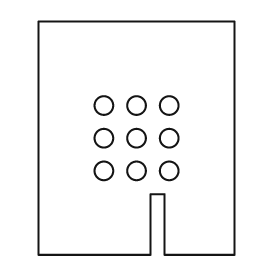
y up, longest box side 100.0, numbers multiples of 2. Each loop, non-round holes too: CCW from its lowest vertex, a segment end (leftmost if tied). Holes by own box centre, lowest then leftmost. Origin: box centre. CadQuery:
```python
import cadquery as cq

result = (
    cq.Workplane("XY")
    .moveTo(-42.0, -50.0)
    .lineTo(6.0, -50.0)
    .lineTo(6.0, -24.0)
    .lineTo(12.0, -24.0)
    .lineTo(12.0, -50.0)
    .lineTo(42.0, -50.0)
    .lineTo(42.0, 50.0)
    .lineTo(-42.0, 50.0)
    .close()
    .moveTo(-14.0, -14.0)
    .circle(4.0)
    .moveTo(0.0, -14.0)
    .circle(4.0)
    .moveTo(14.0, -14.0)
    .circle(4.0)
    .moveTo(-14.0, 0.0)
    .circle(4.0)
    .moveTo(0.0, 0.0)
    .circle(4.0)
    .moveTo(14.0, 0.0)
    .circle(4.0)
    .moveTo(-14.0, 14.0)
    .circle(4.0)
    .moveTo(0.0, 14.0)
    .circle(4.0)
    .moveTo(14.0, 14.0)
    .circle(4.0)
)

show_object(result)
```